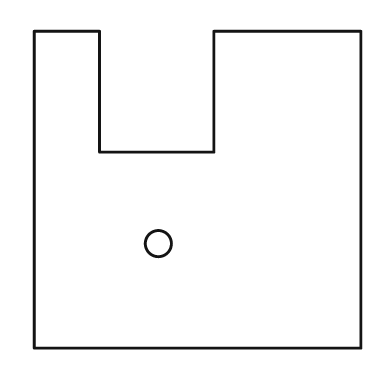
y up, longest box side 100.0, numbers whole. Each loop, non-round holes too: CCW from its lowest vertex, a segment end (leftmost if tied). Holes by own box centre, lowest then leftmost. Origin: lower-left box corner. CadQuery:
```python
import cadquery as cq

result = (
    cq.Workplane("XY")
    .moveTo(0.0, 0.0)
    .lineTo(100.0, 0.0)
    .lineTo(100.0, 97.0)
    .lineTo(55.0, 97.0)
    .lineTo(55.0, 60.0)
    .lineTo(20.0, 60.0)
    .lineTo(20.0, 97.0)
    .lineTo(0.0, 97.0)
    .close()
    .moveTo(38.0, 32.0)
    .circle(4.0)
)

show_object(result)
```